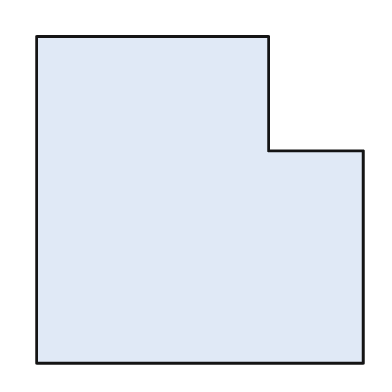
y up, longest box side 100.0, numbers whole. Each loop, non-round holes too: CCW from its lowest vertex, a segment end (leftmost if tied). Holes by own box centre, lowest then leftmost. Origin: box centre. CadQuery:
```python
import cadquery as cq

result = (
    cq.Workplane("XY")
    .moveTo(-50.0, -50.0)
    .lineTo(50.0, -50.0)
    .lineTo(50.0, 15.0)
    .lineTo(21.0, 15.0)
    .lineTo(21.0, 50.0)
    .lineTo(-50.0, 50.0)
    .close()
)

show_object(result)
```